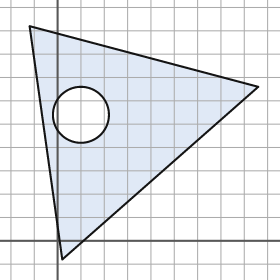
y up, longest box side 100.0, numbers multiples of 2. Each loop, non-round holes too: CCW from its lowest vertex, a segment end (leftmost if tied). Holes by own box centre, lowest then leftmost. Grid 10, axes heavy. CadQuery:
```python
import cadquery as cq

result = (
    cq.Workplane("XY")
    .moveTo(2.0, -8.0)
    .lineTo(86.0, 66.0)
    .lineTo(-12.0, 92.0)
    .close()
    .moveTo(10.0, 54.0)
    .circle(12.0)
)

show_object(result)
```